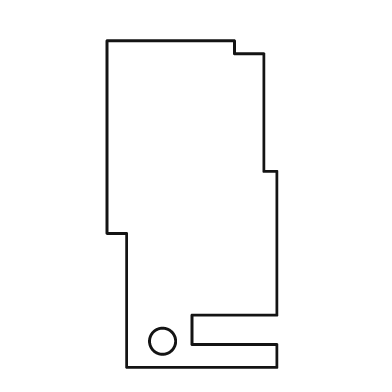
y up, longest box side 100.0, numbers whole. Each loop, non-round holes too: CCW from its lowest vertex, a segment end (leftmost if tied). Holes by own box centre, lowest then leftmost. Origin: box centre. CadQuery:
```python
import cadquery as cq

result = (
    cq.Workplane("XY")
    .moveTo(-20.0, -50.0)
    .lineTo(26.0, -50.0)
    .lineTo(26.0, -43.0)
    .lineTo(0.0, -43.0)
    .lineTo(0.0, -34.0)
    .lineTo(26.0, -34.0)
    .lineTo(26.0, 10.0)
    .lineTo(22.0, 10.0)
    .lineTo(22.0, 46.0)
    .lineTo(13.0, 46.0)
    .lineTo(13.0, 50.0)
    .lineTo(-26.0, 50.0)
    .lineTo(-26.0, -9.0)
    .lineTo(-20.0, -9.0)
    .close()
    .moveTo(-9.0, -42.0)
    .circle(4.0)
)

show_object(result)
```